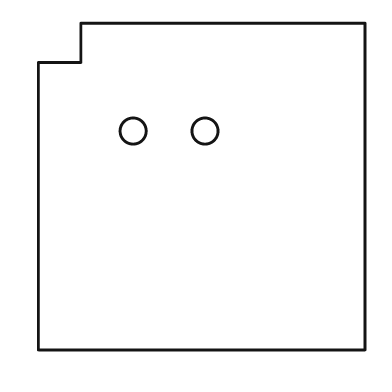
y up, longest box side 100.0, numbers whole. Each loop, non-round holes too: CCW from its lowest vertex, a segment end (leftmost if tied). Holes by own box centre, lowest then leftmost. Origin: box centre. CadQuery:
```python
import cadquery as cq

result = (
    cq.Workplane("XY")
    .moveTo(-50.0, -50.0)
    .lineTo(50.0, -50.0)
    .lineTo(50.0, 50.0)
    .lineTo(-37.0, 50.0)
    .lineTo(-37.0, 38.0)
    .lineTo(-50.0, 38.0)
    .close()
    .moveTo(-21.0, 17.0)
    .circle(4.0)
    .moveTo(1.0, 17.0)
    .circle(4.0)
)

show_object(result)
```